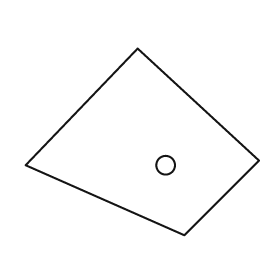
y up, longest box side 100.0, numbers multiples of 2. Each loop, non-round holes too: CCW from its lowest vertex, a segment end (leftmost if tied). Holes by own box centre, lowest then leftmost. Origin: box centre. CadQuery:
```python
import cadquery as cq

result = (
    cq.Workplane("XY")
    .moveTo(18.0, -40.0)
    .lineTo(50.0, -8.0)
    .lineTo(-2.0, 40.0)
    .lineTo(-50.0, -10.0)
    .close()
    .moveTo(10.0, -10.0)
    .circle(4.0)
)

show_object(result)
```